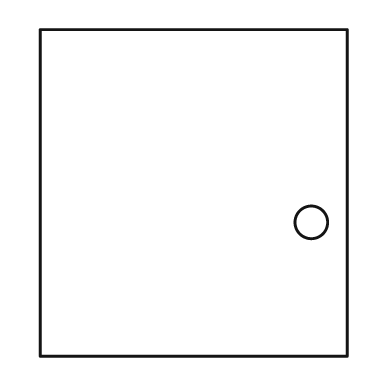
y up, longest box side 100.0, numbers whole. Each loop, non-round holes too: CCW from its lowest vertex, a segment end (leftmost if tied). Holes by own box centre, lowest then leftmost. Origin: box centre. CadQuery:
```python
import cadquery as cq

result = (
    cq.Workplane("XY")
    .moveTo(-47.0, -50.0)
    .lineTo(47.0, -50.0)
    .lineTo(47.0, 50.0)
    .lineTo(-47.0, 50.0)
    .close()
    .moveTo(36.0, -9.0)
    .circle(5.0)
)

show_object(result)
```